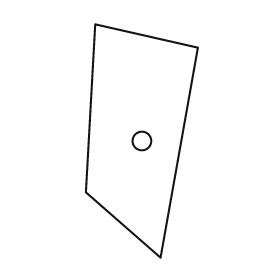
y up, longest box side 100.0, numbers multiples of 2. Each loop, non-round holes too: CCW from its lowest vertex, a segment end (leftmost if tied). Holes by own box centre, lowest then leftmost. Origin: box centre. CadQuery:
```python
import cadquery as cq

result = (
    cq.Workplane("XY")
    .moveTo(8.0, -50.0)
    .lineTo(24.0, 40.0)
    .lineTo(-20.0, 50.0)
    .lineTo(-24.0, -22.0)
    .close()
    .moveTo(0.0, 0.0)
    .circle(4.0)
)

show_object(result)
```